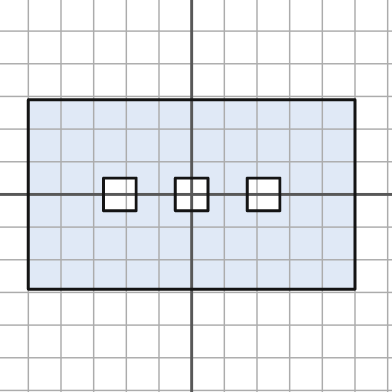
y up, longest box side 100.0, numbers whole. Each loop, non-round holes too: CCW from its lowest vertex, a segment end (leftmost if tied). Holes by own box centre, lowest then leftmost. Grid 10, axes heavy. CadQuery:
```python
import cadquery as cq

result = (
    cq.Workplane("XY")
    .moveTo(-50.0, -29.0)
    .lineTo(50.0, -29.0)
    .lineTo(50.0, 29.0)
    .lineTo(-50.0, 29.0)
    .close()
    .moveTo(-27.0, -5.0)
    .lineTo(-17.0, -5.0)
    .lineTo(-17.0, 5.0)
    .lineTo(-27.0, 5.0)
    .close()
    .moveTo(-5.0, -5.0)
    .lineTo(5.0, -5.0)
    .lineTo(5.0, 5.0)
    .lineTo(-5.0, 5.0)
    .close()
    .moveTo(17.0, -5.0)
    .lineTo(27.0, -5.0)
    .lineTo(27.0, 5.0)
    .lineTo(17.0, 5.0)
    .close()
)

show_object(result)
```